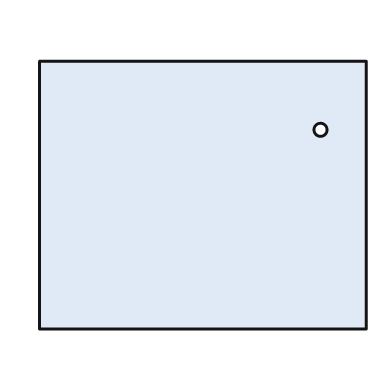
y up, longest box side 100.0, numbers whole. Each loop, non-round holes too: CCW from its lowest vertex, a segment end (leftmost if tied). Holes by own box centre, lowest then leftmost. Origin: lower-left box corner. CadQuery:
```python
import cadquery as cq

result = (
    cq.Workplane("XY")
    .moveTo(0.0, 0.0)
    .lineTo(100.0, 0.0)
    .lineTo(100.0, 82.0)
    .lineTo(0.0, 82.0)
    .close()
    .moveTo(86.0, 61.0)
    .circle(2.0)
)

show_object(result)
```